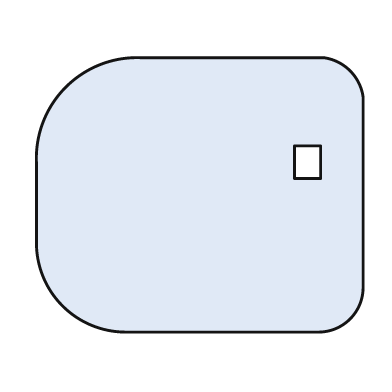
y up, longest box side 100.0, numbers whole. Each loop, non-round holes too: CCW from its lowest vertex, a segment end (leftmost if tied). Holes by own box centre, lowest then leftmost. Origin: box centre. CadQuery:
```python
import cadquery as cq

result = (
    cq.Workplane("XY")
    .moveTo(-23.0, -42.0)
    .lineTo(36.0, -42.0)
    .threePointArc((46.0, -38.0), (50.0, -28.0))
    .lineTo(50.0, 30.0)
    .threePointArc((46.0, 38.0), (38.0, 42.0))
    .lineTo(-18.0, 42.0)
    .threePointArc((-41.0, 33.0), (-50.0, 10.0))
    .lineTo(-50.0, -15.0)
    .threePointArc((-42.0, -34.0), (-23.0, -42.0))
    .close()
    .moveTo(29.0, 5.0)
    .lineTo(37.0, 5.0)
    .lineTo(37.0, 15.0)
    .lineTo(29.0, 15.0)
    .close()
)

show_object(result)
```